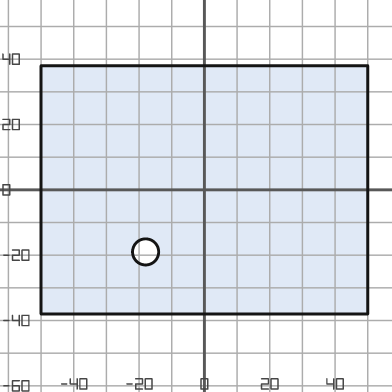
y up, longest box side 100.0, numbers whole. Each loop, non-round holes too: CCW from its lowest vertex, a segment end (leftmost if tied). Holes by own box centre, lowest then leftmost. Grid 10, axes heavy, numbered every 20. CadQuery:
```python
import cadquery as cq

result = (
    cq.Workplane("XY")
    .moveTo(-50.0, -38.0)
    .lineTo(50.0, -38.0)
    .lineTo(50.0, 38.0)
    .lineTo(-50.0, 38.0)
    .close()
    .moveTo(-18.0, -19.0)
    .circle(4.0)
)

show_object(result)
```